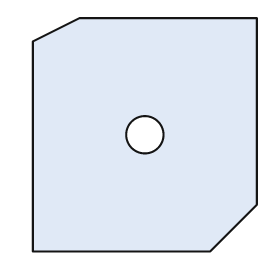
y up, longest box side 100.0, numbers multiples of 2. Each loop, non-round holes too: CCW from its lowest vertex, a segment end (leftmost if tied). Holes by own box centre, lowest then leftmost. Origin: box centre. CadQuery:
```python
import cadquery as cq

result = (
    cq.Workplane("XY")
    .moveTo(-48.0, -50.0)
    .lineTo(28.0, -50.0)
    .lineTo(48.0, -30.0)
    .lineTo(48.0, 50.0)
    .lineTo(-28.0, 50.0)
    .lineTo(-48.0, 40.0)
    .close()
    .moveTo(0.0, 0.0)
    .circle(8.0)
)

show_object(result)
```